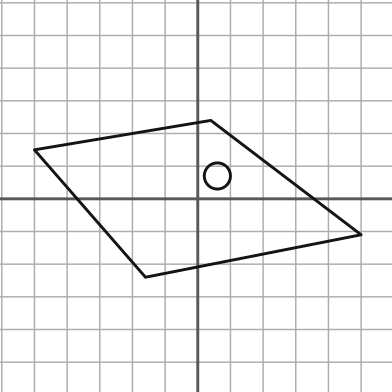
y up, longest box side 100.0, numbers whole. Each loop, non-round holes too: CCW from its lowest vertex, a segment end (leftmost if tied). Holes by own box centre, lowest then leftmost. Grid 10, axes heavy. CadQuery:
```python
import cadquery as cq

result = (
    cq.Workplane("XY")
    .moveTo(-16.0, -24.0)
    .lineTo(50.0, -11.0)
    .lineTo(4.0, 24.0)
    .lineTo(-50.0, 15.0)
    .close()
    .moveTo(6.0, 7.0)
    .circle(4.0)
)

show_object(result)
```